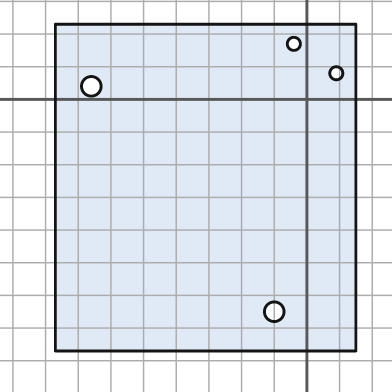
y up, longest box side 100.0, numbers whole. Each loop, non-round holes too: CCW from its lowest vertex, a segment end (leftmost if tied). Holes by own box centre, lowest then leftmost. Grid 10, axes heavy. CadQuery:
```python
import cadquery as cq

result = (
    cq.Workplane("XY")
    .moveTo(-77.0, -77.0)
    .lineTo(15.0, -77.0)
    .lineTo(15.0, 23.0)
    .lineTo(-77.0, 23.0)
    .close()
    .moveTo(-10.0, -65.0)
    .circle(3.0)
    .moveTo(-66.0, 4.0)
    .circle(3.0)
    .moveTo(9.0, 8.0)
    .circle(2.0)
    .moveTo(-4.0, 17.0)
    .circle(2.0)
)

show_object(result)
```